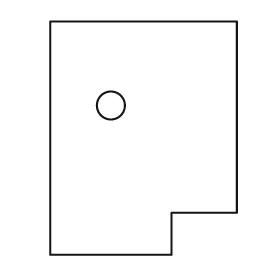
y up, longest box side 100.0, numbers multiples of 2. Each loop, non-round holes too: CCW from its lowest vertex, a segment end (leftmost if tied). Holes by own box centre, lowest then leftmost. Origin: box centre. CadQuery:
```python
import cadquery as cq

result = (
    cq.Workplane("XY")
    .moveTo(-40.0, -50.0)
    .lineTo(12.0, -50.0)
    .lineTo(12.0, -32.0)
    .lineTo(40.0, -32.0)
    .lineTo(40.0, 50.0)
    .lineTo(-40.0, 50.0)
    .close()
    .moveTo(-14.0, 14.0)
    .circle(6.0)
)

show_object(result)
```